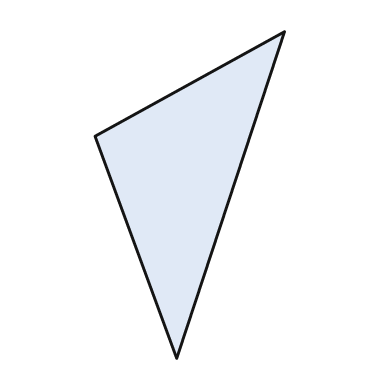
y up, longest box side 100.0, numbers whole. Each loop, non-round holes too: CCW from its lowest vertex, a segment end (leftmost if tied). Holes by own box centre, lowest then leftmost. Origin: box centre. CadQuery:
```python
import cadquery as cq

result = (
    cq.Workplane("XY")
    .moveTo(-4.0, -50.0)
    .lineTo(29.0, 50.0)
    .lineTo(-29.0, 18.0)
    .close()
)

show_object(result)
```